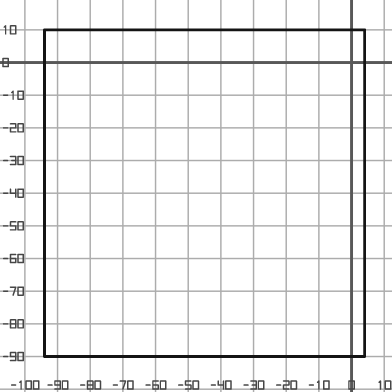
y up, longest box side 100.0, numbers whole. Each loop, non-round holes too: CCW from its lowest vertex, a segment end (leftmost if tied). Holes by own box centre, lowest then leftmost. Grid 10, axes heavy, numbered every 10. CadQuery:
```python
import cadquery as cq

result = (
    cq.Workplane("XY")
    .moveTo(-94.0, -90.0)
    .lineTo(4.0, -90.0)
    .lineTo(4.0, 10.0)
    .lineTo(-94.0, 10.0)
    .close()
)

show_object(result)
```